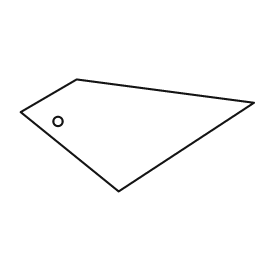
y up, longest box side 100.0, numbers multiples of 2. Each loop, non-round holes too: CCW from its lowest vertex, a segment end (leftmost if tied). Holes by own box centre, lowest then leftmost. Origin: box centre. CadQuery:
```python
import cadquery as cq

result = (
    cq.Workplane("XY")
    .moveTo(-8.0, -24.0)
    .lineTo(50.0, 14.0)
    .lineTo(-26.0, 24.0)
    .lineTo(-50.0, 10.0)
    .close()
    .moveTo(-34.0, 6.0)
    .circle(2.0)
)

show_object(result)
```